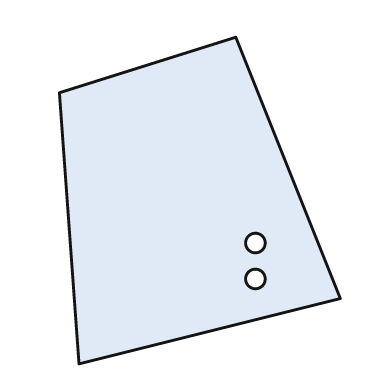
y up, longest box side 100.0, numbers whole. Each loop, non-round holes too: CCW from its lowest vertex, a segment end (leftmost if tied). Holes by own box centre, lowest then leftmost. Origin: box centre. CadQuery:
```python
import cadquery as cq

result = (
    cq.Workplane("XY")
    .moveTo(-37.0, -50.0)
    .lineTo(43.0, -30.0)
    .lineTo(11.0, 50.0)
    .lineTo(-43.0, 33.0)
    .close()
    .moveTo(17.0, -24.0)
    .circle(3.0)
    .moveTo(17.0, -13.0)
    .circle(3.0)
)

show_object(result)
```